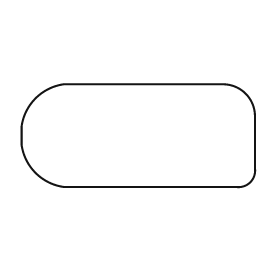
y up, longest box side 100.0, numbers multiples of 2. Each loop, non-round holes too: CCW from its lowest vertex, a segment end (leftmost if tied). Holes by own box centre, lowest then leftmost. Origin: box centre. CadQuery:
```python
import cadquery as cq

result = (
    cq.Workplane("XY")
    .moveTo(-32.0, -22.0)
    .lineTo(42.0, -22.0)
    .threePointArc((48.0, -20.0), (50.0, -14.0))
    .lineTo(50.0, 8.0)
    .threePointArc((46.0, 18.0), (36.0, 22.0))
    .lineTo(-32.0, 22.0)
    .threePointArc((-44.0, 16.0), (-50.0, 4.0))
    .lineTo(-50.0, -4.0)
    .threePointArc((-44.0, -16.0), (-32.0, -22.0))
    .close()
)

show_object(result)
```